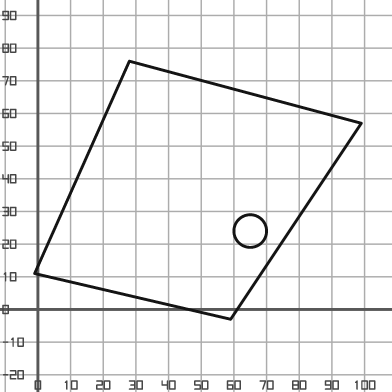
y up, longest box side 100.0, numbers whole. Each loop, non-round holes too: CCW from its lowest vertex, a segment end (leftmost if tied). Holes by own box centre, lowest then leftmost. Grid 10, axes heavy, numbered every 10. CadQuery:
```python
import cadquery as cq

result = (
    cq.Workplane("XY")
    .moveTo(59.0, -3.0)
    .lineTo(99.0, 57.0)
    .lineTo(28.0, 76.0)
    .lineTo(-1.0, 11.0)
    .close()
    .moveTo(65.0, 24.0)
    .circle(5.0)
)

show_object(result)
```